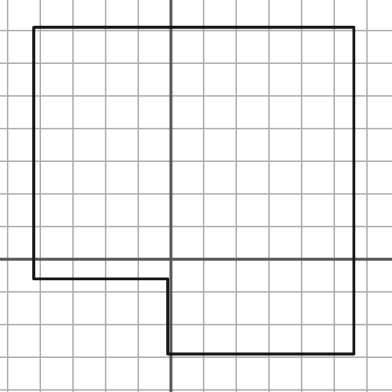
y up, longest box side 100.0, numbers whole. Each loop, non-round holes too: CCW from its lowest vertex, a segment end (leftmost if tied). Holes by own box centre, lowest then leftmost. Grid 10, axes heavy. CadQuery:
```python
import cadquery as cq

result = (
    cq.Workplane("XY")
    .moveTo(-1.0, -29.0)
    .lineTo(56.0, -29.0)
    .lineTo(56.0, 71.0)
    .lineTo(-42.0, 71.0)
    .lineTo(-42.0, -6.0)
    .lineTo(-1.0, -6.0)
    .close()
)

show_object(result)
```